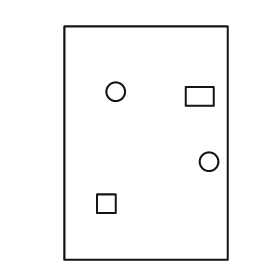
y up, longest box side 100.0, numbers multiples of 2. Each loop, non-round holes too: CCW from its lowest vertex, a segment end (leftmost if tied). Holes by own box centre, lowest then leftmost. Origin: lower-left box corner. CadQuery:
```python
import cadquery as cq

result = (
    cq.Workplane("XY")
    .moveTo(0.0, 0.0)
    .lineTo(70.0, 0.0)
    .lineTo(70.0, 100.0)
    .lineTo(0.0, 100.0)
    .close()
    .moveTo(14.0, 20.0)
    .lineTo(22.0, 20.0)
    .lineTo(22.0, 28.0)
    .lineTo(14.0, 28.0)
    .close()
    .moveTo(62.0, 42.0)
    .circle(4.0)
    .moveTo(52.0, 66.0)
    .lineTo(64.0, 66.0)
    .lineTo(64.0, 74.0)
    .lineTo(52.0, 74.0)
    .close()
    .moveTo(22.0, 72.0)
    .circle(4.0)
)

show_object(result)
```